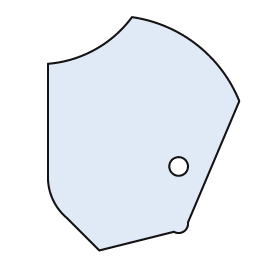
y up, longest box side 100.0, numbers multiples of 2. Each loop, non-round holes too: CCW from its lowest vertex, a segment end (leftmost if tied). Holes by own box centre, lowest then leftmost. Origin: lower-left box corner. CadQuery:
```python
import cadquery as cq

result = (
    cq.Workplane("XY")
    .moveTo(22.0, 0.0)
    .lineTo(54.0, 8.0)
    .threePointArc((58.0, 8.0), (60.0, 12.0))
    .lineTo(82.0, 64.0)
    .threePointArc((64.0, 88.0), (36.0, 100.0))
    .threePointArc((20.0, 86.0), (0.0, 80.0))
    .lineTo(0.0, 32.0)
    .threePointArc((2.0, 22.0), (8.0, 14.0))
    .close()
    .moveTo(56.0, 36.0)
    .circle(4.0)
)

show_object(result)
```